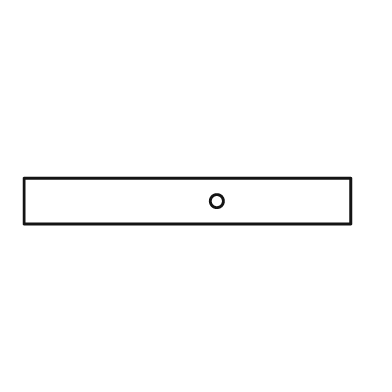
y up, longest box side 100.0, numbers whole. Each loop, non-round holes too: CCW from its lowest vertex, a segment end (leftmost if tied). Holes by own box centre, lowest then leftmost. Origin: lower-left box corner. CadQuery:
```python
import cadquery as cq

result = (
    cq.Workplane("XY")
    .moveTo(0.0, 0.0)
    .lineTo(100.0, 0.0)
    .lineTo(100.0, 14.0)
    .lineTo(0.0, 14.0)
    .close()
    .moveTo(59.0, 7.0)
    .circle(2.0)
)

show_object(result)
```